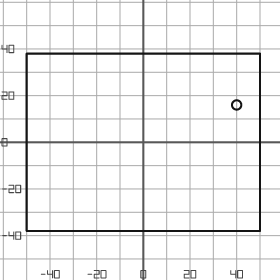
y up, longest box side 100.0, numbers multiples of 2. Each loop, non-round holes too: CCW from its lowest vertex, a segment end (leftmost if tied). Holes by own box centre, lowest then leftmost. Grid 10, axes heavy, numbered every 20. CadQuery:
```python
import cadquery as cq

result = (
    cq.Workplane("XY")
    .moveTo(-50.0, -38.0)
    .lineTo(50.0, -38.0)
    .lineTo(50.0, 38.0)
    .lineTo(-50.0, 38.0)
    .close()
    .moveTo(40.0, 16.0)
    .circle(2.0)
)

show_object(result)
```